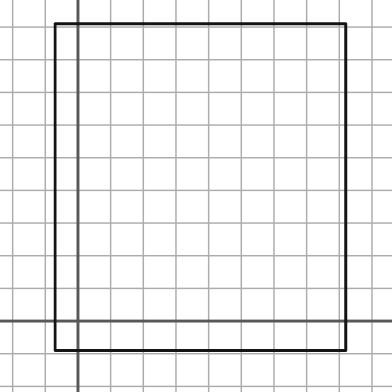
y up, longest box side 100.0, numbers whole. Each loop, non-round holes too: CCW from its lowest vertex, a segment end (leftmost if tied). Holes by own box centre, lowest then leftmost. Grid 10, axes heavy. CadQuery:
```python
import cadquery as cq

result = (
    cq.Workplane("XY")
    .moveTo(-7.0, -9.0)
    .lineTo(82.0, -9.0)
    .lineTo(82.0, 91.0)
    .lineTo(-7.0, 91.0)
    .close()
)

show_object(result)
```